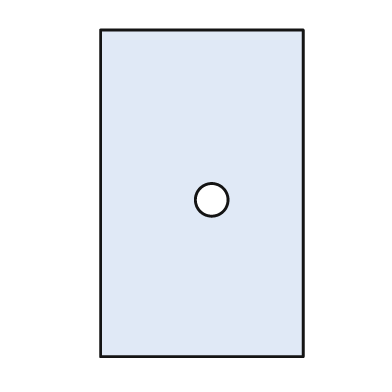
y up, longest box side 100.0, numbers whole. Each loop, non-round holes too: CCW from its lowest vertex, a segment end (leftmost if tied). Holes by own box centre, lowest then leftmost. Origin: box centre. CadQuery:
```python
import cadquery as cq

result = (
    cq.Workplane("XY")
    .moveTo(-31.0, -50.0)
    .lineTo(31.0, -50.0)
    .lineTo(31.0, 50.0)
    .lineTo(-31.0, 50.0)
    .close()
    .moveTo(3.0, -2.0)
    .circle(5.0)
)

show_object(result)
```